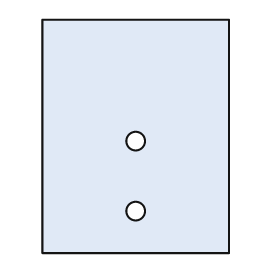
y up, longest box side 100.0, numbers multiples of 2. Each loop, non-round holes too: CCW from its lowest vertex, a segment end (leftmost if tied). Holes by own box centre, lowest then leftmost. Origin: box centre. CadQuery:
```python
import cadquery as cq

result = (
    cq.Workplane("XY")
    .moveTo(-40.0, -50.0)
    .lineTo(40.0, -50.0)
    .lineTo(40.0, 50.0)
    .lineTo(-40.0, 50.0)
    .close()
    .moveTo(0.0, -32.0)
    .circle(4.0)
    .moveTo(0.0, -2.0)
    .circle(4.0)
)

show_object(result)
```